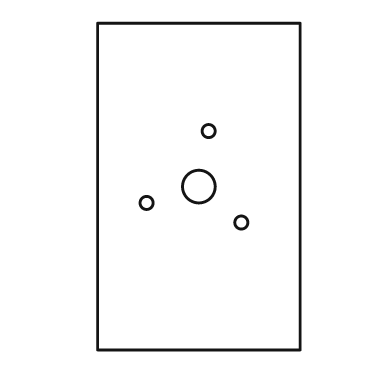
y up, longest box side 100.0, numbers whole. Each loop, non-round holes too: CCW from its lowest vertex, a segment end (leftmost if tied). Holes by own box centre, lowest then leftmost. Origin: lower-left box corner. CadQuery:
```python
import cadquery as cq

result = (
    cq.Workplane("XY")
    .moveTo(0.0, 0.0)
    .lineTo(62.0, 0.0)
    .lineTo(62.0, 100.0)
    .lineTo(0.0, 100.0)
    .close()
    .moveTo(44.0, 39.0)
    .circle(2.0)
    .moveTo(15.0, 45.0)
    .circle(2.0)
    .moveTo(31.0, 50.0)
    .circle(5.0)
    .moveTo(34.0, 67.0)
    .circle(2.0)
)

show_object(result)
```